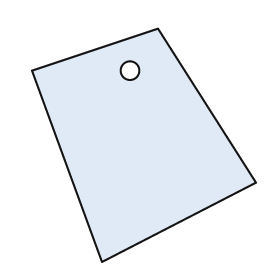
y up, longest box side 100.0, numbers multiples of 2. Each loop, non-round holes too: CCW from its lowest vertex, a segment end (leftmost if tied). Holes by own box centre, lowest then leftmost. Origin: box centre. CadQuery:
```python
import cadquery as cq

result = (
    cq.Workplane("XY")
    .moveTo(-18.0, -50.0)
    .lineTo(48.0, -16.0)
    .lineTo(6.0, 50.0)
    .lineTo(-48.0, 32.0)
    .close()
    .moveTo(-6.0, 32.0)
    .circle(4.0)
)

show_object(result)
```